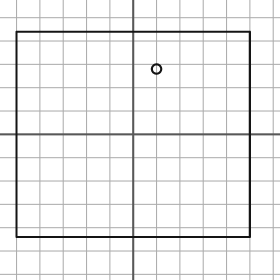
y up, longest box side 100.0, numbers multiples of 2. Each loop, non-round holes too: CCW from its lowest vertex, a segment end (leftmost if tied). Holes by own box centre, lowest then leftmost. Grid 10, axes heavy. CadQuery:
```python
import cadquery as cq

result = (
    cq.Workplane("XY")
    .moveTo(-50.0, -44.0)
    .lineTo(50.0, -44.0)
    .lineTo(50.0, 44.0)
    .lineTo(-50.0, 44.0)
    .close()
    .moveTo(10.0, 28.0)
    .circle(2.0)
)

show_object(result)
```